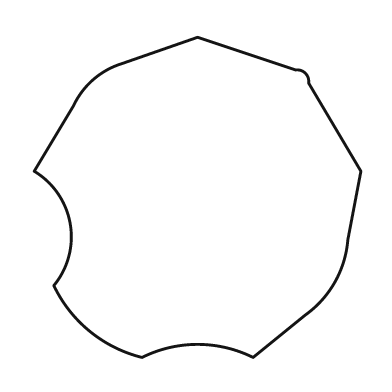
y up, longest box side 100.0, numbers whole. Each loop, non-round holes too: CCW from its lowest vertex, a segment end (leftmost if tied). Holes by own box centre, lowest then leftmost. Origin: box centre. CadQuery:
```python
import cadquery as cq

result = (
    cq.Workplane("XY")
    .moveTo(-17.0, -49.0)
    .threePointArc((0.0, -45.0), (17.0, -49.0))
    .lineTo(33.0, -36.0)
    .threePointArc((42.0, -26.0), (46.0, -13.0))
    .lineTo(50.0, 8.0)
    .lineTo(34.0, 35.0)
    .threePointArc((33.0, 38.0), (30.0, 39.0))
    .lineTo(0.0, 49.0)
    .lineTo(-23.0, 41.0)
    .threePointArc((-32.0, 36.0), (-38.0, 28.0))
    .lineTo(-50.0, 8.0)
    .threePointArc((-39.0, -8.0), (-44.0, -27.0))
    .threePointArc((-33.0, -41.0), (-17.0, -49.0))
    .close()
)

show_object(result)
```